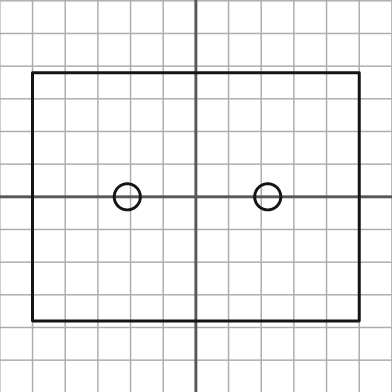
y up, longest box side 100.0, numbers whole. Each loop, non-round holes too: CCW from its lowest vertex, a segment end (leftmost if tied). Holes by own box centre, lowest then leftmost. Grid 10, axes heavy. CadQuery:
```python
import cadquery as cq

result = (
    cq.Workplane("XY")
    .moveTo(-50.0, -38.0)
    .lineTo(50.0, -38.0)
    .lineTo(50.0, 38.0)
    .lineTo(-50.0, 38.0)
    .close()
    .moveTo(-21.0, 0.0)
    .circle(4.0)
    .moveTo(22.0, 0.0)
    .circle(4.0)
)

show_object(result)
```